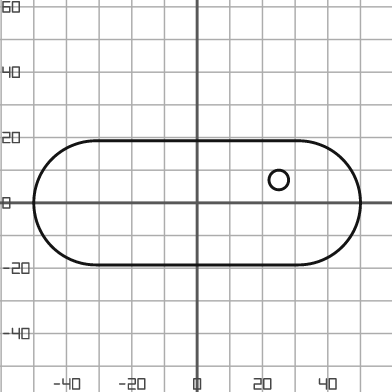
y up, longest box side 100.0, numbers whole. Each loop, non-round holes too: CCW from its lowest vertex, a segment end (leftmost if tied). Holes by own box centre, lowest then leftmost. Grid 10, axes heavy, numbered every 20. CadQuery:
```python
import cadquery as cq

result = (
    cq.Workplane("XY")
    .moveTo(-31.0, -19.0)
    .lineTo(31.0, -19.0)
    .threePointArc((50.0, 0.0), (31.0, 19.0))
    .lineTo(-31.0, 19.0)
    .threePointArc((-50.0, 0.0), (-31.0, -19.0))
    .close()
    .moveTo(25.0, 7.0)
    .circle(3.0)
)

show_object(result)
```